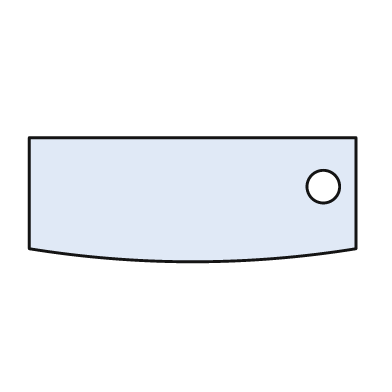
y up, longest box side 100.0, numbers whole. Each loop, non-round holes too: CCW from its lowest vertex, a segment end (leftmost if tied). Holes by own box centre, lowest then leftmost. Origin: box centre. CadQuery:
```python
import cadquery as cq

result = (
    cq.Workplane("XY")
    .moveTo(-50.0, -15.0)
    .threePointArc((0.0, -19.0), (50.0, -15.0))
    .lineTo(50.0, 19.0)
    .lineTo(-50.0, 19.0)
    .close()
    .moveTo(40.0, 4.0)
    .circle(5.0)
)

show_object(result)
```